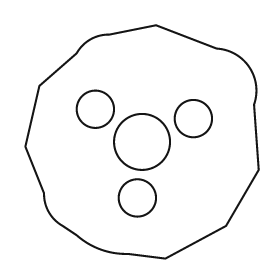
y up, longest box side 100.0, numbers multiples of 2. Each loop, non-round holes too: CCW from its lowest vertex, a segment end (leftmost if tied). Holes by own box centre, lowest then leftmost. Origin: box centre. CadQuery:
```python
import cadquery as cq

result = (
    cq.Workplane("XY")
    .moveTo(10.0, -50.0)
    .lineTo(36.0, -36.0)
    .lineTo(50.0, -12.0)
    .lineTo(48.0, 16.0)
    .threePointArc((46.0, 32.0), (32.0, 40.0))
    .lineTo(6.0, 50.0)
    .lineTo(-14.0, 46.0)
    .threePointArc((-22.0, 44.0), (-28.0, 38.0))
    .lineTo(-44.0, 24.0)
    .lineTo(-50.0, -2.0)
    .lineTo(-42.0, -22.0)
    .threePointArc((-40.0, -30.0), (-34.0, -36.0))
    .lineTo(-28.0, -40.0)
    .threePointArc((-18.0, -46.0), (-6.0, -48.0))
    .close()
    .moveTo(-2.0, -24.0)
    .circle(8.0)
    .moveTo(0.0, 0.0)
    .circle(12.0)
    .moveTo(22.0, 10.0)
    .circle(8.0)
    .moveTo(-20.0, 14.0)
    .circle(8.0)
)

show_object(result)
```